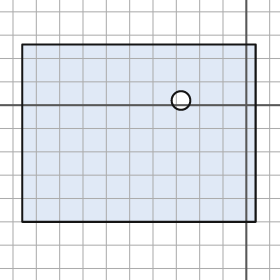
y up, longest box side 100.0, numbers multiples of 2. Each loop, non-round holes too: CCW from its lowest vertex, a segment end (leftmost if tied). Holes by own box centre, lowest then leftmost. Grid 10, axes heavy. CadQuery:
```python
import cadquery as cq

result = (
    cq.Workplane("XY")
    .moveTo(-96.0, -50.0)
    .lineTo(4.0, -50.0)
    .lineTo(4.0, 26.0)
    .lineTo(-96.0, 26.0)
    .close()
    .moveTo(-28.0, 2.0)
    .circle(4.0)
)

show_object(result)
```